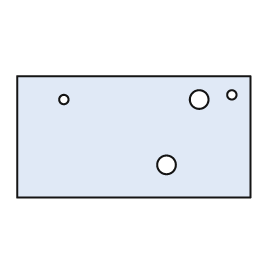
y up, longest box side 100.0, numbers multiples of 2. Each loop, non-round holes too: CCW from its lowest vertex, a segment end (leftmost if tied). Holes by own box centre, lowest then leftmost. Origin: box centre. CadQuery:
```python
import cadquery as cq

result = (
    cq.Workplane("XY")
    .moveTo(-50.0, -26.0)
    .lineTo(50.0, -26.0)
    .lineTo(50.0, 26.0)
    .lineTo(-50.0, 26.0)
    .close()
    .moveTo(14.0, -12.0)
    .circle(4.0)
    .moveTo(-30.0, 16.0)
    .circle(2.0)
    .moveTo(28.0, 16.0)
    .circle(4.0)
    .moveTo(42.0, 18.0)
    .circle(2.0)
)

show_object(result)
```